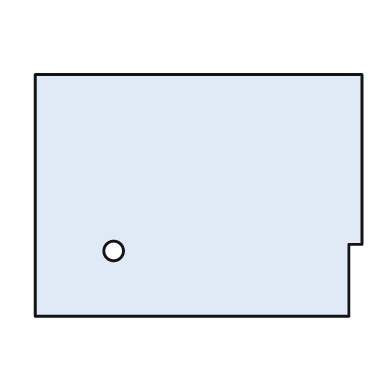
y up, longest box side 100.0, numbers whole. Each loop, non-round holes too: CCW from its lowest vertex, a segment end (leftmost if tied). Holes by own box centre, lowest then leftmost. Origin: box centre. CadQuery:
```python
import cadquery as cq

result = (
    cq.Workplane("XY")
    .moveTo(-50.0, -37.0)
    .lineTo(46.0, -37.0)
    .lineTo(46.0, -15.0)
    .lineTo(50.0, -15.0)
    .lineTo(50.0, 37.0)
    .lineTo(-50.0, 37.0)
    .close()
    .moveTo(-26.0, -17.0)
    .circle(3.0)
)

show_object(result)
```